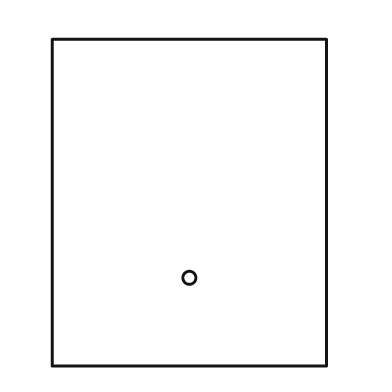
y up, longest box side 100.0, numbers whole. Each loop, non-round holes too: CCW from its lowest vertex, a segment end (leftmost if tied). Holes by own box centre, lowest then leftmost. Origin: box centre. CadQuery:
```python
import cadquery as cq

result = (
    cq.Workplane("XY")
    .moveTo(-42.0, -50.0)
    .lineTo(42.0, -50.0)
    .lineTo(42.0, 50.0)
    .lineTo(-42.0, 50.0)
    .close()
    .moveTo(0.0, -23.0)
    .circle(2.0)
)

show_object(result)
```